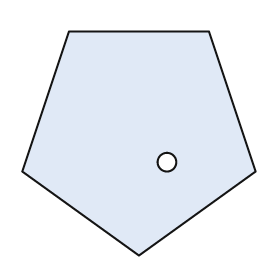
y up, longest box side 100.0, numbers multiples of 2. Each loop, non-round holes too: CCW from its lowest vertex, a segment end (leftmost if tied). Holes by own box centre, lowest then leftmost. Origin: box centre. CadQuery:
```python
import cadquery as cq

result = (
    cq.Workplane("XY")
    .moveTo(0.0, -48.0)
    .lineTo(50.0, -12.0)
    .lineTo(30.0, 48.0)
    .lineTo(-30.0, 48.0)
    .lineTo(-50.0, -12.0)
    .close()
    .moveTo(12.0, -8.0)
    .circle(4.0)
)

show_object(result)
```